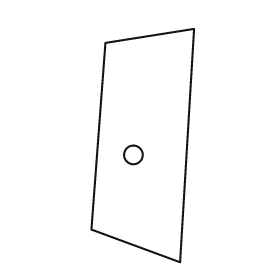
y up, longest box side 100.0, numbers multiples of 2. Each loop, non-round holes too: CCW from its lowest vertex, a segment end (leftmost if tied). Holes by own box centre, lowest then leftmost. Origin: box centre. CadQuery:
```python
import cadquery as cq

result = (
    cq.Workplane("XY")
    .moveTo(16.0, -50.0)
    .lineTo(22.0, 50.0)
    .lineTo(-16.0, 44.0)
    .lineTo(-22.0, -36.0)
    .close()
    .moveTo(-4.0, -4.0)
    .circle(4.0)
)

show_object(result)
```